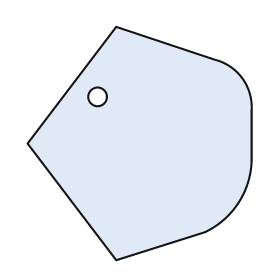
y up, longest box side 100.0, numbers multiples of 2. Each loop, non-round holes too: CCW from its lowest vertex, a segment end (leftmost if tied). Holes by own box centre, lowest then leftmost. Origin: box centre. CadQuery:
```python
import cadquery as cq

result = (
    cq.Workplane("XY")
    .moveTo(-10.0, -50.0)
    .lineTo(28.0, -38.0)
    .threePointArc((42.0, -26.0), (48.0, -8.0))
    .lineTo(48.0, 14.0)
    .threePointArc((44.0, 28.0), (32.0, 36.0))
    .lineTo(-10.0, 50.0)
    .lineTo(-48.0, 0.0)
    .close()
    .moveTo(-18.0, 20.0)
    .circle(4.0)
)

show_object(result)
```